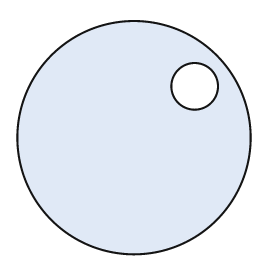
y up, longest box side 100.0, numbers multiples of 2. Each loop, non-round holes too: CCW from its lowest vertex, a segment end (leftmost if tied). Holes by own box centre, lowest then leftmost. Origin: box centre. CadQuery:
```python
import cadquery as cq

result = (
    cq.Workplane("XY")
    .moveTo(0.0, 0.0)
    .circle(50.0)
    .moveTo(26.0, 22.0)
    .circle(10.0)
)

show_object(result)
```